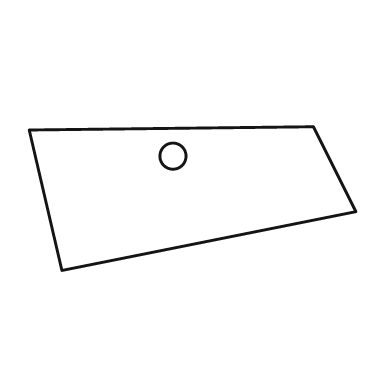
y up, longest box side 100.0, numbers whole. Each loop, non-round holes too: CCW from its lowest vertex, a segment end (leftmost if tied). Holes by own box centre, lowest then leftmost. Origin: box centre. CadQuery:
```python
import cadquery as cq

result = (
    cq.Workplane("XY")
    .moveTo(-40.0, -22.0)
    .lineTo(50.0, -4.0)
    .lineTo(37.0, 22.0)
    .lineTo(-50.0, 21.0)
    .close()
    .moveTo(-6.0, 13.0)
    .circle(4.0)
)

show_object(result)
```